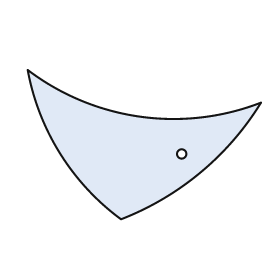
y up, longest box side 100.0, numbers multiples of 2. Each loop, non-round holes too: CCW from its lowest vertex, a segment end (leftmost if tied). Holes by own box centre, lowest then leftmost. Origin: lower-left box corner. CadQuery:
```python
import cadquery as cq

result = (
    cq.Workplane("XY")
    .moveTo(40.0, 0.0)
    .threePointArc((74.0, 20.0), (100.0, 50.0))
    .threePointArc((48.0, 44.0), (0.0, 64.0))
    .threePointArc((14.0, 28.0), (40.0, 0.0))
    .close()
    .moveTo(66.0, 28.0)
    .circle(2.0)
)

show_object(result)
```